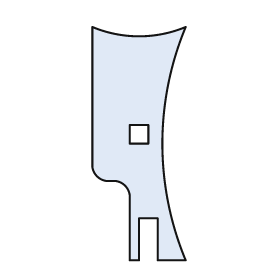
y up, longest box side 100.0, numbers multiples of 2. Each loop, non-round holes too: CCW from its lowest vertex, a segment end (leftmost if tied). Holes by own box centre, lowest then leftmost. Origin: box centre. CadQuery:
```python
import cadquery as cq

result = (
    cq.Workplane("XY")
    .moveTo(-4.0, -50.0)
    .lineTo(0.0, -50.0)
    .lineTo(0.0, -32.0)
    .lineTo(8.0, -32.0)
    .lineTo(8.0, -50.0)
    .lineTo(20.0, -50.0)
    .threePointArc((10.0, 0.0), (20.0, 50.0))
    .threePointArc((0.0, 46.0), (-20.0, 50.0))
    .lineTo(-20.0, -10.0)
    .threePointArc((-18.0, -14.0), (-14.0, -16.0))
    .lineTo(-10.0, -16.0)
    .threePointArc((-6.0, -18.0), (-4.0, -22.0))
    .close()
    .moveTo(-4.0, 0.0)
    .lineTo(4.0, 0.0)
    .lineTo(4.0, 8.0)
    .lineTo(-4.0, 8.0)
    .close()
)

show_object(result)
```